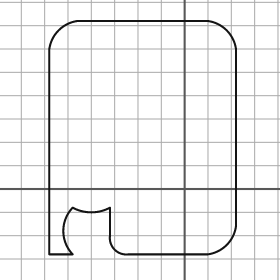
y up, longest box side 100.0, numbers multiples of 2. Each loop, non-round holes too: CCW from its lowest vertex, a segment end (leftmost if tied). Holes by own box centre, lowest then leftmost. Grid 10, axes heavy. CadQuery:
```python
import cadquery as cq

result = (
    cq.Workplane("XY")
    .moveTo(-58.0, -28.0)
    .lineTo(-48.0, -28.0)
    .threePointArc((-52.0, -18.0), (-48.0, -8.0))
    .threePointArc((-40.0, -10.0), (-32.0, -8.0))
    .lineTo(-32.0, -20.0)
    .threePointArc((-30.0, -26.0), (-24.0, -28.0))
    .lineTo(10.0, -28.0)
    .threePointArc((18.0, -24.0), (22.0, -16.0))
    .lineTo(22.0, 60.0)
    .threePointArc((18.0, 68.0), (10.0, 72.0))
    .lineTo(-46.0, 72.0)
    .threePointArc((-54.0, 68.0), (-58.0, 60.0))
    .close()
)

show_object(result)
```